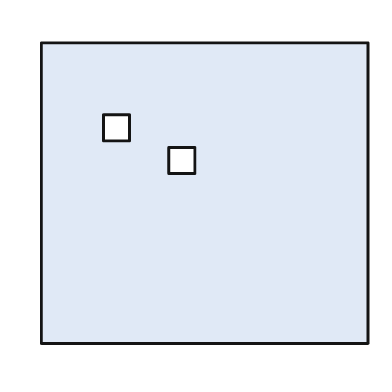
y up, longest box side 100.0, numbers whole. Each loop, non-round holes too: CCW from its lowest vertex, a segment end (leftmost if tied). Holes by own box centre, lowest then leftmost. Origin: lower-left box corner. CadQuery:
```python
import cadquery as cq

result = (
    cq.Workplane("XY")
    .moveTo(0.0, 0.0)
    .lineTo(100.0, 0.0)
    .lineTo(100.0, 92.0)
    .lineTo(0.0, 92.0)
    .close()
    .moveTo(39.0, 52.0)
    .lineTo(47.0, 52.0)
    .lineTo(47.0, 60.0)
    .lineTo(39.0, 60.0)
    .close()
    .moveTo(19.0, 62.0)
    .lineTo(27.0, 62.0)
    .lineTo(27.0, 70.0)
    .lineTo(19.0, 70.0)
    .close()
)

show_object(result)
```